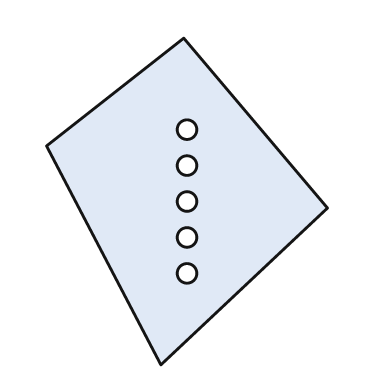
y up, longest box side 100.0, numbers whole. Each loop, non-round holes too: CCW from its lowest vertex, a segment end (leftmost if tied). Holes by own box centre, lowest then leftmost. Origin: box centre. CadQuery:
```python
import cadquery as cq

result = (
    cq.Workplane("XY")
    .moveTo(-8.0, -50.0)
    .lineTo(43.0, -2.0)
    .lineTo(-1.0, 50.0)
    .lineTo(-43.0, 17.0)
    .close()
    .moveTo(0.0, -22.0)
    .circle(3.0)
    .moveTo(0.0, -11.0)
    .circle(3.0)
    .moveTo(0.0, 0.0)
    .circle(3.0)
    .moveTo(0.0, 11.0)
    .circle(3.0)
    .moveTo(0.0, 22.0)
    .circle(3.0)
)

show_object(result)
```